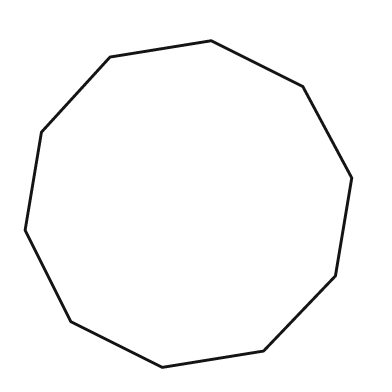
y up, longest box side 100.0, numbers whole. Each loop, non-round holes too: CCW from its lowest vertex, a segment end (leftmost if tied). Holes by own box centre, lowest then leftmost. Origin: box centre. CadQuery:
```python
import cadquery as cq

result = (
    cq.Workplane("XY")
    .moveTo(-8.0, -50.0)
    .lineTo(23.0, -45.0)
    .lineTo(45.0, -22.0)
    .lineTo(50.0, 8.0)
    .lineTo(35.0, 36.0)
    .lineTo(7.0, 50.0)
    .lineTo(-24.0, 45.0)
    .lineTo(-45.0, 22.0)
    .lineTo(-50.0, -8.0)
    .lineTo(-36.0, -36.0)
    .close()
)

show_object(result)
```